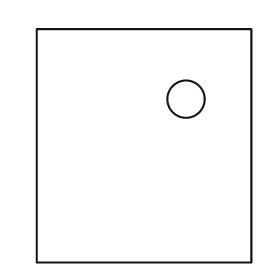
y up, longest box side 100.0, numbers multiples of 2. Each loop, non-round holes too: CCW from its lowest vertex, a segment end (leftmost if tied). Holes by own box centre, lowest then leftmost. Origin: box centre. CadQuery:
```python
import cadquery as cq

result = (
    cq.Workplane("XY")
    .moveTo(-46.0, -50.0)
    .lineTo(46.0, -50.0)
    .lineTo(46.0, 50.0)
    .lineTo(-46.0, 50.0)
    .close()
    .moveTo(18.0, 20.0)
    .circle(8.0)
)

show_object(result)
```